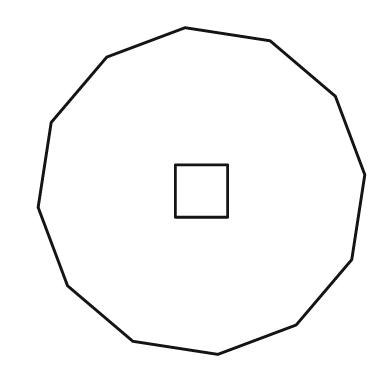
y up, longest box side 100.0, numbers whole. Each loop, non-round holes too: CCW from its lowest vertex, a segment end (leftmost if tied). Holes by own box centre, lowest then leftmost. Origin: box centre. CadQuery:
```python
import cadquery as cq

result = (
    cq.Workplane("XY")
    .moveTo(5.0, -50.0)
    .lineTo(29.0, -41.0)
    .lineTo(46.0, -21.0)
    .lineTo(50.0, 5.0)
    .lineTo(41.0, 29.0)
    .lineTo(21.0, 46.0)
    .lineTo(-5.0, 50.0)
    .lineTo(-29.0, 41.0)
    .lineTo(-46.0, 21.0)
    .lineTo(-50.0, -5.0)
    .lineTo(-41.0, -29.0)
    .lineTo(-21.0, -46.0)
    .close()
    .moveTo(-8.0, -8.0)
    .lineTo(8.0, -8.0)
    .lineTo(8.0, 8.0)
    .lineTo(-8.0, 8.0)
    .close()
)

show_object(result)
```